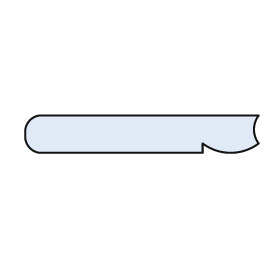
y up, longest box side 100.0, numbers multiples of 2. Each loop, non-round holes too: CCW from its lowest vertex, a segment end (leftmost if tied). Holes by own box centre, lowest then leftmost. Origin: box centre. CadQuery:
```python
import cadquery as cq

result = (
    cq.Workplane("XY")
    .moveTo(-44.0, -8.0)
    .lineTo(26.0, -8.0)
    .lineTo(26.0, -4.0)
    .threePointArc((38.0, -8.0), (50.0, -4.0))
    .threePointArc((48.0, 2.0), (50.0, 8.0))
    .lineTo(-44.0, 8.0)
    .threePointArc((-48.0, 6.0), (-50.0, 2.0))
    .lineTo(-50.0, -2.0)
    .threePointArc((-48.0, -6.0), (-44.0, -8.0))
    .close()
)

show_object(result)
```